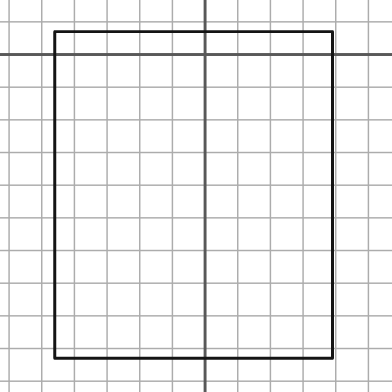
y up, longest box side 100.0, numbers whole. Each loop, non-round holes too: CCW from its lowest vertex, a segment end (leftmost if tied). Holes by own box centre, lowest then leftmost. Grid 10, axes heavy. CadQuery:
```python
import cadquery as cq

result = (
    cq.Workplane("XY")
    .moveTo(-46.0, -93.0)
    .lineTo(39.0, -93.0)
    .lineTo(39.0, 7.0)
    .lineTo(-46.0, 7.0)
    .close()
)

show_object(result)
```